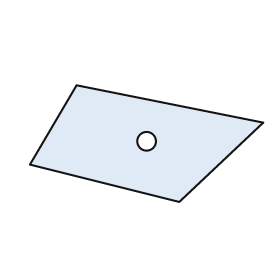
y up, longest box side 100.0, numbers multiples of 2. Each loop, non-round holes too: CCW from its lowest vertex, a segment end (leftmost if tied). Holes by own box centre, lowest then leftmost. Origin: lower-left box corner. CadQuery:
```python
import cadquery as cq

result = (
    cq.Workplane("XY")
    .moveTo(64.0, 0.0)
    .lineTo(100.0, 34.0)
    .lineTo(20.0, 50.0)
    .lineTo(0.0, 16.0)
    .close()
    .moveTo(50.0, 26.0)
    .circle(4.0)
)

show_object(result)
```